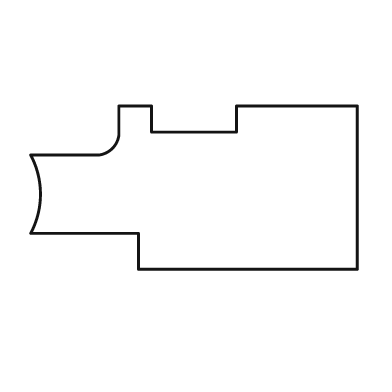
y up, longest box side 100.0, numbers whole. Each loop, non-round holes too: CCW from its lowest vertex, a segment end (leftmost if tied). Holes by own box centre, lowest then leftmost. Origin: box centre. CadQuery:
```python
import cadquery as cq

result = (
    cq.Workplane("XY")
    .moveTo(-17.0, -25.0)
    .lineTo(50.0, -25.0)
    .lineTo(50.0, 25.0)
    .lineTo(13.0, 25.0)
    .lineTo(13.0, 17.0)
    .lineTo(-13.0, 17.0)
    .lineTo(-13.0, 25.0)
    .lineTo(-23.0, 25.0)
    .lineTo(-23.0, 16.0)
    .threePointArc((-25.0, 12.0), (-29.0, 10.0))
    .lineTo(-50.0, 10.0)
    .threePointArc((-47.0, -2.0), (-50.0, -14.0))
    .lineTo(-17.0, -14.0)
    .close()
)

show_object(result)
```